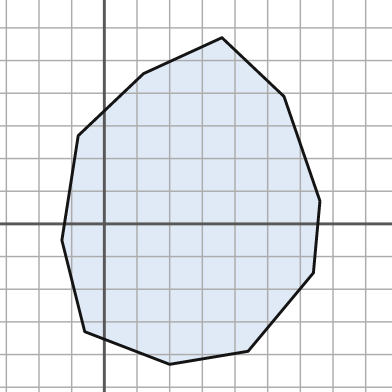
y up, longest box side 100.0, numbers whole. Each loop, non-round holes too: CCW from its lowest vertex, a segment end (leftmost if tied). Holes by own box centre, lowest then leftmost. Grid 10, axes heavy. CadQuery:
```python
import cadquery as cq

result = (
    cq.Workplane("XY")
    .moveTo(20.0, -43.0)
    .lineTo(44.0, -39.0)
    .lineTo(64.0, -15.0)
    .lineTo(66.0, 7.0)
    .lineTo(55.0, 39.0)
    .lineTo(36.0, 57.0)
    .lineTo(12.0, 46.0)
    .lineTo(-8.0, 27.0)
    .lineTo(-13.0, -5.0)
    .lineTo(-6.0, -33.0)
    .close()
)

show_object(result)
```